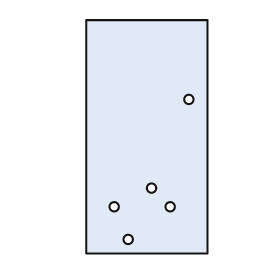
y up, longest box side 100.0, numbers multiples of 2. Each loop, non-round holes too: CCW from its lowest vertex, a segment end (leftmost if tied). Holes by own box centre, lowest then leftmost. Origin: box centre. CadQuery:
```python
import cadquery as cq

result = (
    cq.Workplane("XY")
    .moveTo(-26.0, -50.0)
    .lineTo(26.0, -50.0)
    .lineTo(26.0, 50.0)
    .lineTo(-26.0, 50.0)
    .close()
    .moveTo(-8.0, -44.0)
    .circle(2.0)
    .moveTo(-14.0, -30.0)
    .circle(2.0)
    .moveTo(10.0, -30.0)
    .circle(2.0)
    .moveTo(2.0, -22.0)
    .circle(2.0)
    .moveTo(18.0, 16.0)
    .circle(2.0)
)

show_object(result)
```